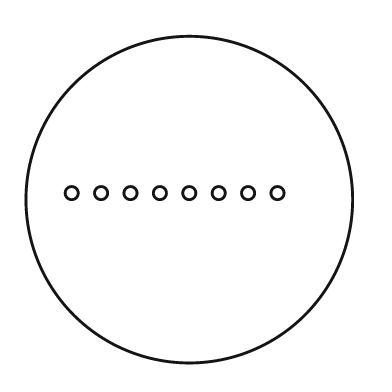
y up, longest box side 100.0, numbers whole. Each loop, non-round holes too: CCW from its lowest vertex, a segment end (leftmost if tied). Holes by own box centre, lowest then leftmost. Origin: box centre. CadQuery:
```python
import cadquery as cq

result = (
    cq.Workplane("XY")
    .moveTo(0.0, 0.0)
    .circle(50.0)
    .moveTo(-36.0, 2.0)
    .circle(2.0)
    .moveTo(-27.0, 2.0)
    .circle(2.0)
    .moveTo(-18.0, 2.0)
    .circle(2.0)
    .moveTo(-9.0, 2.0)
    .circle(2.0)
    .moveTo(0.0, 2.0)
    .circle(2.0)
    .moveTo(9.0, 2.0)
    .circle(2.0)
    .moveTo(18.0, 2.0)
    .circle(2.0)
    .moveTo(27.0, 2.0)
    .circle(2.0)
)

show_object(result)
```